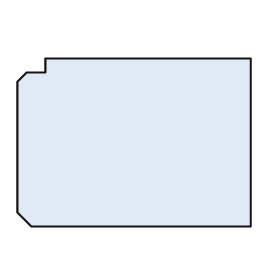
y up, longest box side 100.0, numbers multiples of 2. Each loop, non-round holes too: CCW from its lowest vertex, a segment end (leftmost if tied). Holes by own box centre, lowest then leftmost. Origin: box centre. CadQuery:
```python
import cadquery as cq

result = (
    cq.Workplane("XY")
    .moveTo(-44.0, -36.0)
    .lineTo(50.0, -36.0)
    .lineTo(50.0, 36.0)
    .lineTo(-38.0, 36.0)
    .lineTo(-38.0, 30.0)
    .lineTo(-46.0, 30.0)
    .lineTo(-50.0, 26.0)
    .lineTo(-50.0, -30.0)
    .close()
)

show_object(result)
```